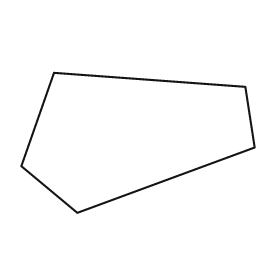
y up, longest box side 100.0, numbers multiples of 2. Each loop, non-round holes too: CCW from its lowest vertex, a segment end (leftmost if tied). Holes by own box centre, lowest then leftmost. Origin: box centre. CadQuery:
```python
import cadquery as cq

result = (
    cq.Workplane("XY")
    .moveTo(-26.0, -30.0)
    .lineTo(50.0, -2.0)
    .lineTo(46.0, 24.0)
    .lineTo(-36.0, 30.0)
    .lineTo(-50.0, -10.0)
    .close()
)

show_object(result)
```